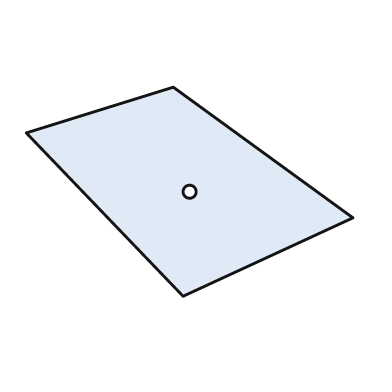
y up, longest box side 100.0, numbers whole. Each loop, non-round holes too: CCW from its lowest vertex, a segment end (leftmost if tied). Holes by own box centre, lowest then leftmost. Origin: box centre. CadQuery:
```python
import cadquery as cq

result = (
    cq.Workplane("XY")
    .moveTo(-2.0, -32.0)
    .lineTo(50.0, -8.0)
    .lineTo(-5.0, 32.0)
    .lineTo(-50.0, 18.0)
    .close()
    .moveTo(0.0, 0.0)
    .circle(2.0)
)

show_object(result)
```